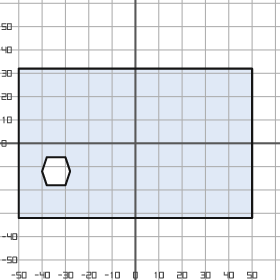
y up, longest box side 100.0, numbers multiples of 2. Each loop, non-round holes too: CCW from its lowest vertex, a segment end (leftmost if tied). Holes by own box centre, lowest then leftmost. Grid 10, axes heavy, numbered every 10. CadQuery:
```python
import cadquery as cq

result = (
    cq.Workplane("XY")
    .moveTo(-50.0, -32.0)
    .lineTo(50.0, -32.0)
    .lineTo(50.0, 32.0)
    .lineTo(-50.0, 32.0)
    .close()
    .moveTo(-38.0, -18.0)
    .lineTo(-30.0, -18.0)
    .lineTo(-28.0, -12.0)
    .lineTo(-30.0, -6.0)
    .lineTo(-38.0, -6.0)
    .lineTo(-40.0, -12.0)
    .close()
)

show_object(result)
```